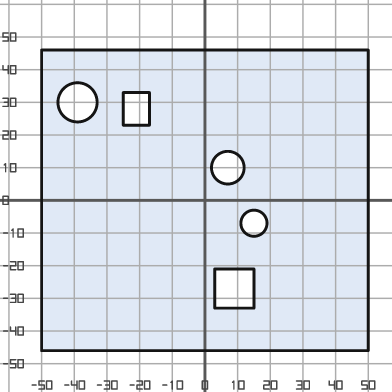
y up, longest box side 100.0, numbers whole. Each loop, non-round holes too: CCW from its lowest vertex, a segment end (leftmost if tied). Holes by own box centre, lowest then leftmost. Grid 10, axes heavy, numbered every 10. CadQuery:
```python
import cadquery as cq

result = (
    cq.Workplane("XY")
    .moveTo(-50.0, -46.0)
    .lineTo(50.0, -46.0)
    .lineTo(50.0, 46.0)
    .lineTo(-50.0, 46.0)
    .close()
    .moveTo(3.0, -33.0)
    .lineTo(15.0, -33.0)
    .lineTo(15.0, -21.0)
    .lineTo(3.0, -21.0)
    .close()
    .moveTo(15.0, -7.0)
    .circle(4.0)
    .moveTo(7.0, 10.0)
    .circle(5.0)
    .moveTo(-25.0, 23.0)
    .lineTo(-17.0, 23.0)
    .lineTo(-17.0, 33.0)
    .lineTo(-25.0, 33.0)
    .close()
    .moveTo(-39.0, 30.0)
    .circle(6.0)
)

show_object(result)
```